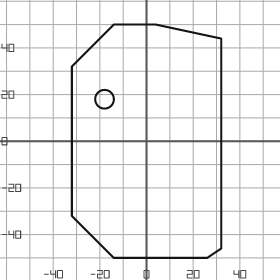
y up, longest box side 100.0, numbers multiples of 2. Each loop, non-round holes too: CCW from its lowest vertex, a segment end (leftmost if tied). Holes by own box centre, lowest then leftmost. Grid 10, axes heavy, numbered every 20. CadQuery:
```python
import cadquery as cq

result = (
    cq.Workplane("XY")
    .moveTo(-14.0, -50.0)
    .lineTo(26.0, -50.0)
    .lineTo(32.0, -46.0)
    .lineTo(32.0, 44.0)
    .lineTo(4.0, 50.0)
    .lineTo(-14.0, 50.0)
    .lineTo(-32.0, 32.0)
    .lineTo(-32.0, -32.0)
    .close()
    .moveTo(-18.0, 18.0)
    .circle(4.0)
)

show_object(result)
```